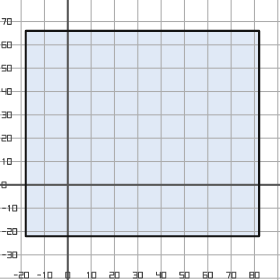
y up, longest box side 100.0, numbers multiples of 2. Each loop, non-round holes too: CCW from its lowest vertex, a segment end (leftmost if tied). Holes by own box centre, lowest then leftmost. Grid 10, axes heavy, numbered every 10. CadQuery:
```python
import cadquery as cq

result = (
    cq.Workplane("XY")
    .moveTo(-18.0, -22.0)
    .lineTo(82.0, -22.0)
    .lineTo(82.0, 66.0)
    .lineTo(-18.0, 66.0)
    .close()
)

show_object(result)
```